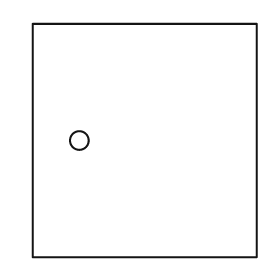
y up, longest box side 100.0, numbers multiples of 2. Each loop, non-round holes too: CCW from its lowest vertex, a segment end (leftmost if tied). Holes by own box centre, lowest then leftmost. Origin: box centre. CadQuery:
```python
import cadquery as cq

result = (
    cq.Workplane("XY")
    .moveTo(-48.0, -50.0)
    .lineTo(48.0, -50.0)
    .lineTo(48.0, 50.0)
    .lineTo(-48.0, 50.0)
    .close()
    .moveTo(-28.0, 0.0)
    .circle(4.0)
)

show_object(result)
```